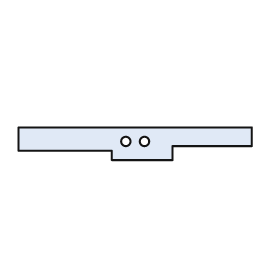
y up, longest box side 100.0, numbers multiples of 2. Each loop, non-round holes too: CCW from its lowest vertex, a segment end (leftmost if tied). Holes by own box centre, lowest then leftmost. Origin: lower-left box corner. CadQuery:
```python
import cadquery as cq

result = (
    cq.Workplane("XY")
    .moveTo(40.0, 0.0)
    .lineTo(66.0, 0.0)
    .lineTo(66.0, 6.0)
    .lineTo(100.0, 6.0)
    .lineTo(100.0, 14.0)
    .lineTo(0.0, 14.0)
    .lineTo(0.0, 4.0)
    .lineTo(40.0, 4.0)
    .close()
    .moveTo(46.0, 8.0)
    .circle(2.0)
    .moveTo(54.0, 8.0)
    .circle(2.0)
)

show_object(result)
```